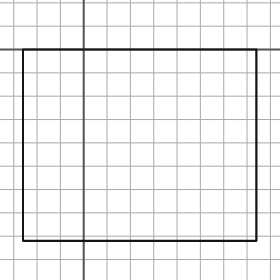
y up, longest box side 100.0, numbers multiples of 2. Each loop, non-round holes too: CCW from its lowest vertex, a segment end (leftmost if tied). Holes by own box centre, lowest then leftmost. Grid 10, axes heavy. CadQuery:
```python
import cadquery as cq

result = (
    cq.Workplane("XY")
    .moveTo(-26.0, -82.0)
    .lineTo(74.0, -82.0)
    .lineTo(74.0, 0.0)
    .lineTo(-26.0, 0.0)
    .close()
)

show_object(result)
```